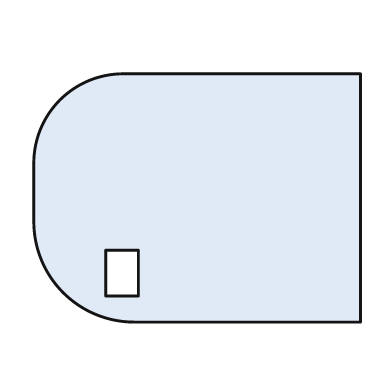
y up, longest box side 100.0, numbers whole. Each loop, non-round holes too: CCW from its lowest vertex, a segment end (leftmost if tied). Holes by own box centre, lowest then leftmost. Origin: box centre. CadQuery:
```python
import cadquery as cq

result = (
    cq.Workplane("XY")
    .moveTo(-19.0, -38.0)
    .lineTo(50.0, -38.0)
    .lineTo(50.0, 38.0)
    .lineTo(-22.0, 38.0)
    .threePointArc((-42.0, 30.0), (-50.0, 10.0))
    .lineTo(-50.0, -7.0)
    .threePointArc((-41.0, -29.0), (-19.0, -38.0))
    .close()
    .moveTo(-28.0, -30.0)
    .lineTo(-18.0, -30.0)
    .lineTo(-18.0, -16.0)
    .lineTo(-28.0, -16.0)
    .close()
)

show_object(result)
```